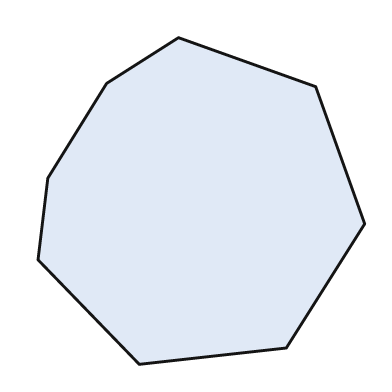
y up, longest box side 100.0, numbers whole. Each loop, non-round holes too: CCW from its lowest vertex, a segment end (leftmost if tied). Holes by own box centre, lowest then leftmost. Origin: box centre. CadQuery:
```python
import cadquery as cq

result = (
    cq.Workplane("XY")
    .moveTo(-19.0, -50.0)
    .lineTo(26.0, -45.0)
    .lineTo(50.0, -7.0)
    .lineTo(35.0, 35.0)
    .lineTo(-7.0, 50.0)
    .lineTo(-29.0, 36.0)
    .lineTo(-47.0, 7.0)
    .lineTo(-50.0, -18.0)
    .close()
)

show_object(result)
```